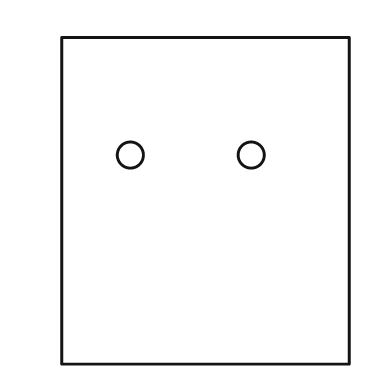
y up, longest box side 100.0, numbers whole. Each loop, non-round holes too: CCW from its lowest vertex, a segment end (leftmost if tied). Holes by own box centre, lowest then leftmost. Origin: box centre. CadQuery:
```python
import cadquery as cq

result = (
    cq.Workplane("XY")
    .moveTo(-44.0, -50.0)
    .lineTo(44.0, -50.0)
    .lineTo(44.0, 50.0)
    .lineTo(-44.0, 50.0)
    .close()
    .moveTo(-23.0, 14.0)
    .circle(4.0)
    .moveTo(14.0, 14.0)
    .circle(4.0)
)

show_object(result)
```